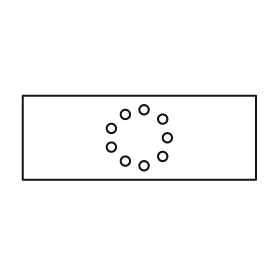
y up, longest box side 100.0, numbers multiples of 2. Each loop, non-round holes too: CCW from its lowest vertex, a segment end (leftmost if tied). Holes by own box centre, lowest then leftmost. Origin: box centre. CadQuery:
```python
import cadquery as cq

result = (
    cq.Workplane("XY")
    .moveTo(-50.0, -18.0)
    .lineTo(50.0, -18.0)
    .lineTo(50.0, 18.0)
    .lineTo(-50.0, 18.0)
    .close()
    .moveTo(2.0, -12.0)
    .circle(2.0)
    .moveTo(-6.0, -10.0)
    .circle(2.0)
    .moveTo(10.0, -8.0)
    .circle(2.0)
    .moveTo(-12.0, -4.0)
    .circle(2.0)
    .moveTo(12.0, 0.0)
    .circle(2.0)
    .moveTo(-12.0, 4.0)
    .circle(2.0)
    .moveTo(10.0, 8.0)
    .circle(2.0)
    .moveTo(-6.0, 10.0)
    .circle(2.0)
    .moveTo(2.0, 12.0)
    .circle(2.0)
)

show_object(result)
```